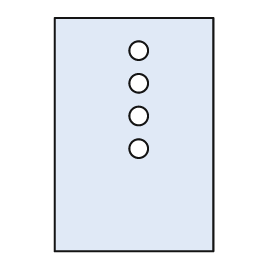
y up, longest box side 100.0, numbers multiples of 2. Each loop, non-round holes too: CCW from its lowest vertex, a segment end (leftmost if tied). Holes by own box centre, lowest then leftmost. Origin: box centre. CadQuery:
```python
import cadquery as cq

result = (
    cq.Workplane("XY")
    .moveTo(-34.0, -50.0)
    .lineTo(34.0, -50.0)
    .lineTo(34.0, 50.0)
    .lineTo(-34.0, 50.0)
    .close()
    .moveTo(2.0, -6.0)
    .circle(4.0)
    .moveTo(2.0, 8.0)
    .circle(4.0)
    .moveTo(2.0, 22.0)
    .circle(4.0)
    .moveTo(2.0, 36.0)
    .circle(4.0)
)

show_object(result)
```